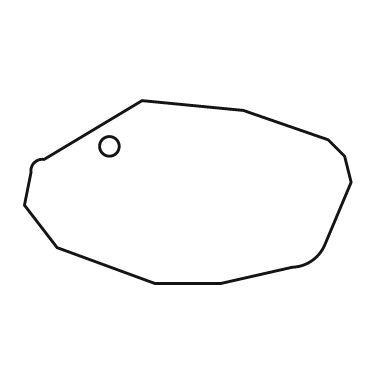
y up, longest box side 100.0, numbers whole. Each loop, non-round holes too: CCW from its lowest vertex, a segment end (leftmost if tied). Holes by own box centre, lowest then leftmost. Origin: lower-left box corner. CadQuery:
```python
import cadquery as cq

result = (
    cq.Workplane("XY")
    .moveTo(40.0, 0.0)
    .lineTo(60.0, 0.0)
    .lineTo(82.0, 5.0)
    .threePointArc((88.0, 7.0), (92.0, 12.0))
    .lineTo(100.0, 31.0)
    .lineTo(98.0, 39.0)
    .lineTo(93.0, 44.0)
    .lineTo(67.0, 53.0)
    .lineTo(36.0, 56.0)
    .lineTo(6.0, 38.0)
    .threePointArc((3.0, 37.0), (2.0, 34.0))
    .lineTo(0.0, 24.0)
    .lineTo(10.0, 11.0)
    .close()
    .moveTo(26.0, 42.0)
    .circle(3.0)
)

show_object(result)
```